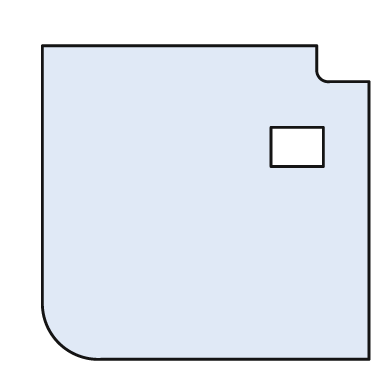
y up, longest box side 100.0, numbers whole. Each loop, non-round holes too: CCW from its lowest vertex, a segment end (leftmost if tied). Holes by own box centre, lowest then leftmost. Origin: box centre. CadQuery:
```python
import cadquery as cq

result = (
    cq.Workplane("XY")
    .moveTo(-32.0, -48.0)
    .lineTo(50.0, -48.0)
    .lineTo(50.0, 37.0)
    .lineTo(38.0, 37.0)
    .threePointArc((35.0, 38.0), (34.0, 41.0))
    .lineTo(34.0, 48.0)
    .lineTo(-50.0, 48.0)
    .lineTo(-50.0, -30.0)
    .threePointArc((-45.0, -43.0), (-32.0, -48.0))
    .close()
    .moveTo(20.0, 11.0)
    .lineTo(36.0, 11.0)
    .lineTo(36.0, 23.0)
    .lineTo(20.0, 23.0)
    .close()
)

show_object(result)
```